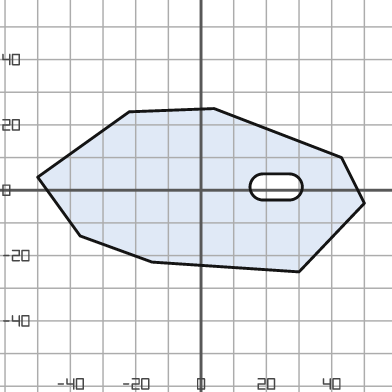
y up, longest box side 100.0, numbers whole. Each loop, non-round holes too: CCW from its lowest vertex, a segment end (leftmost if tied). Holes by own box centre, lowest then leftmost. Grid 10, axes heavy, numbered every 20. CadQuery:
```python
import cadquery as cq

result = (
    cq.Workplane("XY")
    .moveTo(30.0, -25.0)
    .lineTo(50.0, -4.0)
    .lineTo(43.0, 10.0)
    .lineTo(4.0, 25.0)
    .lineTo(-22.0, 24.0)
    .lineTo(-50.0, 4.0)
    .lineTo(-37.0, -14.0)
    .lineTo(-15.0, -22.0)
    .close()
    .moveTo(19.0, -3.0)
    .lineTo(27.0, -3.0)
    .threePointArc((31.0, 1.0), (27.0, 5.0))
    .lineTo(19.0, 5.0)
    .threePointArc((15.0, 1.0), (19.0, -3.0))
    .close()
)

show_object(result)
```